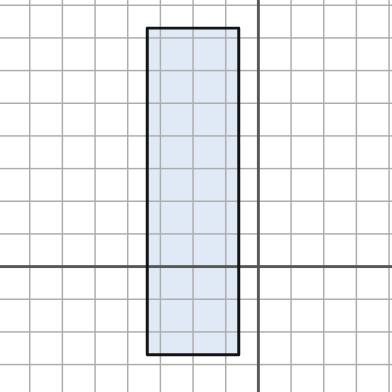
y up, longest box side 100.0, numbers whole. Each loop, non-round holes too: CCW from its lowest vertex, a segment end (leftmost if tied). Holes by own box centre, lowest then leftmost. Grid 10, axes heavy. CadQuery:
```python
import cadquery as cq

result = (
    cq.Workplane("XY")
    .moveTo(-34.0, -27.0)
    .lineTo(-6.0, -27.0)
    .lineTo(-6.0, 73.0)
    .lineTo(-34.0, 73.0)
    .close()
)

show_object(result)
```